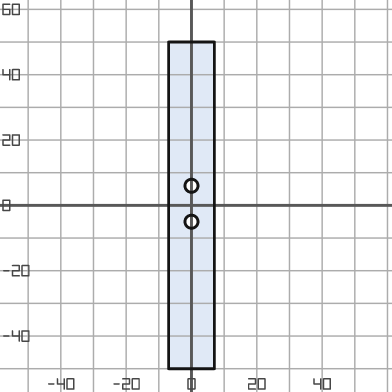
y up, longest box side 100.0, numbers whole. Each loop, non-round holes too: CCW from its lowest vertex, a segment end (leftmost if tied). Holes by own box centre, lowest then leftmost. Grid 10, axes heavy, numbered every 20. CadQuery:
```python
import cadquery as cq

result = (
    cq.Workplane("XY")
    .moveTo(-7.0, -50.0)
    .lineTo(7.0, -50.0)
    .lineTo(7.0, 50.0)
    .lineTo(-7.0, 50.0)
    .close()
    .moveTo(0.0, -5.0)
    .circle(2.0)
    .moveTo(0.0, 6.0)
    .circle(2.0)
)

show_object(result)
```